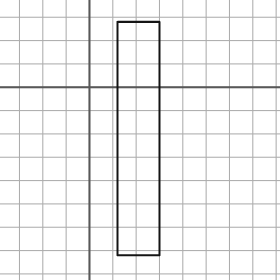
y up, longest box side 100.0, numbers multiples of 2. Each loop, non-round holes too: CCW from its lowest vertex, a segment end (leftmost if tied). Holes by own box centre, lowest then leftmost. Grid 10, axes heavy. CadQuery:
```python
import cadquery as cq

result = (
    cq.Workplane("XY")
    .moveTo(12.0, -72.0)
    .lineTo(30.0, -72.0)
    .lineTo(30.0, 28.0)
    .lineTo(12.0, 28.0)
    .close()
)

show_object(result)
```